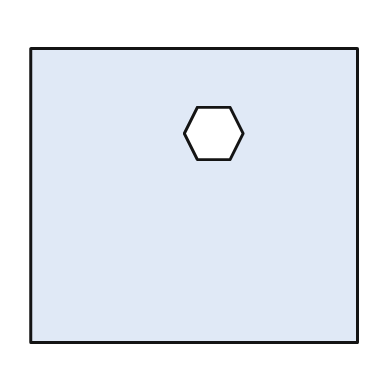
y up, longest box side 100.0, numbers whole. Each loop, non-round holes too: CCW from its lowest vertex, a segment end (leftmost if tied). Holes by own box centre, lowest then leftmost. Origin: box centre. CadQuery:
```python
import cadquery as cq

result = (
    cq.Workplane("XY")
    .moveTo(-50.0, -45.0)
    .lineTo(50.0, -45.0)
    .lineTo(50.0, 45.0)
    .lineTo(-50.0, 45.0)
    .close()
    .moveTo(1.0, 11.0)
    .lineTo(11.0, 11.0)
    .lineTo(15.0, 19.0)
    .lineTo(11.0, 27.0)
    .lineTo(1.0, 27.0)
    .lineTo(-3.0, 19.0)
    .close()
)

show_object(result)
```